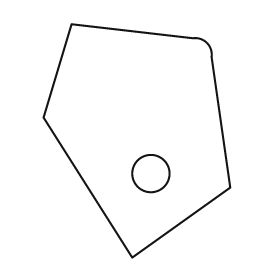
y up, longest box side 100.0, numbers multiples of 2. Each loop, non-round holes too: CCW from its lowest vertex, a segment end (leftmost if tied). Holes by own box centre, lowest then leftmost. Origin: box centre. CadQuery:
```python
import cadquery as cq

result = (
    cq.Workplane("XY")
    .moveTo(-2.0, -50.0)
    .lineTo(40.0, -20.0)
    .lineTo(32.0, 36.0)
    .threePointArc((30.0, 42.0), (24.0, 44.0))
    .lineTo(-28.0, 50.0)
    .lineTo(-40.0, 10.0)
    .close()
    .moveTo(6.0, -14.0)
    .circle(8.0)
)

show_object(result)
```